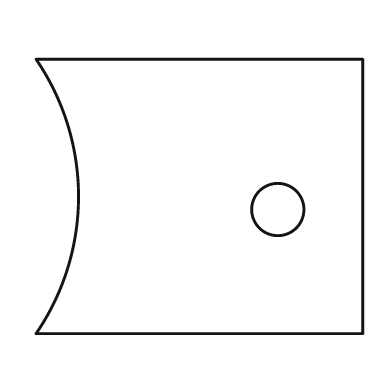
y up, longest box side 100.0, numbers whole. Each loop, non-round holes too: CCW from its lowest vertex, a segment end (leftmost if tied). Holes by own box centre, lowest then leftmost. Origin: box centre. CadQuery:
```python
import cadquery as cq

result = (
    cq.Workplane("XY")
    .moveTo(-50.0, -42.0)
    .lineTo(50.0, -42.0)
    .lineTo(50.0, 42.0)
    .lineTo(-50.0, 42.0)
    .threePointArc((-37.0, 0.0), (-50.0, -42.0))
    .close()
    .moveTo(24.0, -4.0)
    .circle(8.0)
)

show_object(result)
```